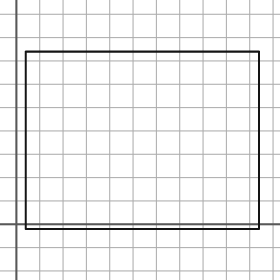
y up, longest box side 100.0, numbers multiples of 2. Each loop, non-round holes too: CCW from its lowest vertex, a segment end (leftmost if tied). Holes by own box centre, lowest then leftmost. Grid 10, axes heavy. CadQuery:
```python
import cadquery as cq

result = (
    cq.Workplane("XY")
    .moveTo(4.0, -2.0)
    .lineTo(104.0, -2.0)
    .lineTo(104.0, 74.0)
    .lineTo(4.0, 74.0)
    .close()
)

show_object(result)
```